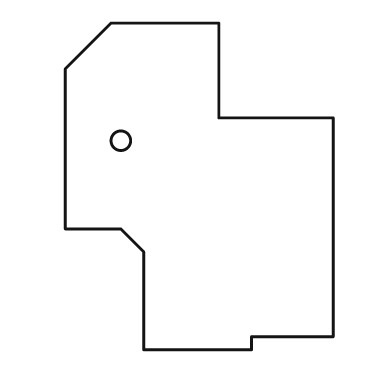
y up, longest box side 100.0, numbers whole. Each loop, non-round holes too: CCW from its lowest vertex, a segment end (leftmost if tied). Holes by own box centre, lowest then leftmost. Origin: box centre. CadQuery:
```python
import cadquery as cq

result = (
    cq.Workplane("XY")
    .moveTo(-17.0, -50.0)
    .lineTo(16.0, -50.0)
    .lineTo(16.0, -46.0)
    .lineTo(41.0, -46.0)
    .lineTo(41.0, 21.0)
    .lineTo(6.0, 21.0)
    .lineTo(6.0, 50.0)
    .lineTo(-27.0, 50.0)
    .lineTo(-41.0, 36.0)
    .lineTo(-41.0, -13.0)
    .lineTo(-24.0, -13.0)
    .lineTo(-17.0, -20.0)
    .close()
    .moveTo(-24.0, 14.0)
    .circle(3.0)
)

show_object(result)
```